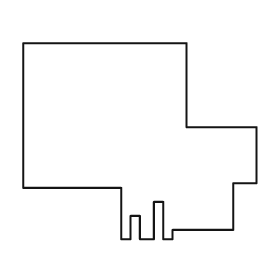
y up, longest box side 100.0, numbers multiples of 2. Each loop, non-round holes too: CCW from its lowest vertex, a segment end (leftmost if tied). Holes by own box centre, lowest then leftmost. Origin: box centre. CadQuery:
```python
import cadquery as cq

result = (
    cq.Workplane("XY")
    .moveTo(-8.0, -42.0)
    .lineTo(-4.0, -42.0)
    .lineTo(-4.0, -32.0)
    .lineTo(0.0, -32.0)
    .lineTo(0.0, -42.0)
    .lineTo(6.0, -42.0)
    .lineTo(6.0, -26.0)
    .lineTo(10.0, -26.0)
    .lineTo(10.0, -42.0)
    .lineTo(14.0, -42.0)
    .lineTo(14.0, -38.0)
    .lineTo(40.0, -38.0)
    .lineTo(40.0, -18.0)
    .lineTo(50.0, -18.0)
    .lineTo(50.0, 6.0)
    .lineTo(20.0, 6.0)
    .lineTo(20.0, 42.0)
    .lineTo(-50.0, 42.0)
    .lineTo(-50.0, -20.0)
    .lineTo(-8.0, -20.0)
    .close()
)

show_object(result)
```